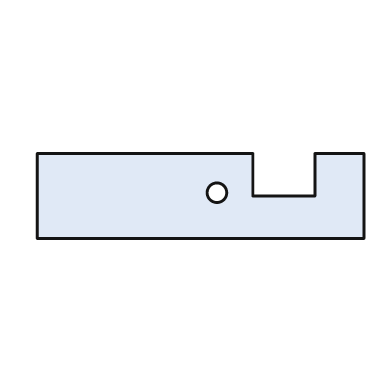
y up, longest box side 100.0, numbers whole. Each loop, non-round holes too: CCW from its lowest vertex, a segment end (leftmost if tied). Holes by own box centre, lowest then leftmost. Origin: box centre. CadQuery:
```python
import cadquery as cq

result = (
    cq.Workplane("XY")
    .moveTo(-50.0, -13.0)
    .lineTo(50.0, -13.0)
    .lineTo(50.0, 13.0)
    .lineTo(35.0, 13.0)
    .lineTo(35.0, 0.0)
    .lineTo(16.0, 0.0)
    .lineTo(16.0, 13.0)
    .lineTo(-50.0, 13.0)
    .close()
    .moveTo(5.0, 1.0)
    .circle(3.0)
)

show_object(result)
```